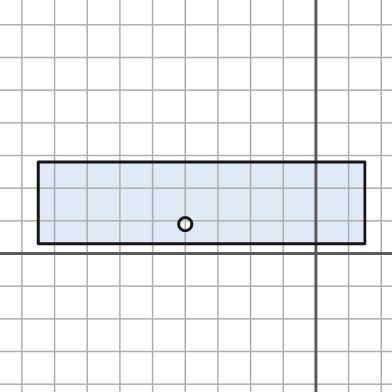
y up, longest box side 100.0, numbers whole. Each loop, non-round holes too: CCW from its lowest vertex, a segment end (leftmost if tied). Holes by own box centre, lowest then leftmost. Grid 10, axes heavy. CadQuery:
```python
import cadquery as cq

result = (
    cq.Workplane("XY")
    .moveTo(-85.0, 3.0)
    .lineTo(15.0, 3.0)
    .lineTo(15.0, 28.0)
    .lineTo(-85.0, 28.0)
    .close()
    .moveTo(-40.0, 9.0)
    .circle(2.0)
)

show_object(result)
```